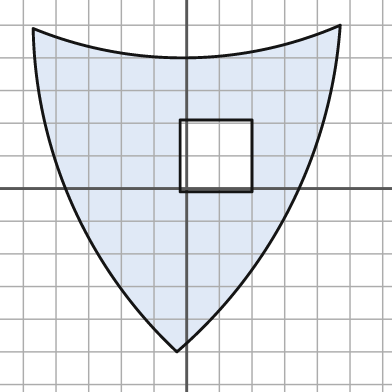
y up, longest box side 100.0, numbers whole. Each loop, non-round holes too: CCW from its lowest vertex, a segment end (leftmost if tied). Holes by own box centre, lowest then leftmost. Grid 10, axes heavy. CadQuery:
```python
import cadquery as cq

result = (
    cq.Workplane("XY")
    .moveTo(-3.0, -50.0)
    .threePointArc((32.0, -5.0), (47.0, 50.0))
    .threePointArc((0.0, 40.0), (-47.0, 49.0))
    .threePointArc((-35.0, -5.0), (-3.0, -50.0))
    .close()
    .moveTo(-2.0, -1.0)
    .lineTo(20.0, -1.0)
    .lineTo(20.0, 21.0)
    .lineTo(-2.0, 21.0)
    .close()
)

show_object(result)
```